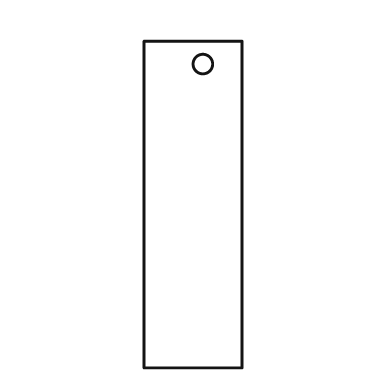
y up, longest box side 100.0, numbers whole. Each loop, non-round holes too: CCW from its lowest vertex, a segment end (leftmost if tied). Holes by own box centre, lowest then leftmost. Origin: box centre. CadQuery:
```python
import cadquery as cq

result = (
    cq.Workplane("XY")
    .moveTo(-15.0, -50.0)
    .lineTo(15.0, -50.0)
    .lineTo(15.0, 50.0)
    .lineTo(-15.0, 50.0)
    .close()
    .moveTo(3.0, 43.0)
    .circle(3.0)
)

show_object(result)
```